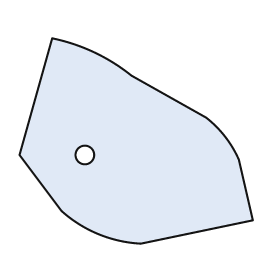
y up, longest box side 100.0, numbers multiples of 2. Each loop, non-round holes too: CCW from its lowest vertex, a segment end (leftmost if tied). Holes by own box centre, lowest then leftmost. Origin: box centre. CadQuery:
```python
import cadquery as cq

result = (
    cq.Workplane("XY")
    .moveTo(2.0, -44.0)
    .lineTo(50.0, -34.0)
    .lineTo(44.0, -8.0)
    .threePointArc((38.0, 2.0), (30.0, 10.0))
    .lineTo(-2.0, 28.0)
    .threePointArc((-18.0, 38.0), (-36.0, 44.0))
    .lineTo(-50.0, -6.0)
    .lineTo(-32.0, -30.0)
    .threePointArc((-16.0, -40.0), (2.0, -44.0))
    .close()
    .moveTo(-22.0, -6.0)
    .circle(4.0)
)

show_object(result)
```